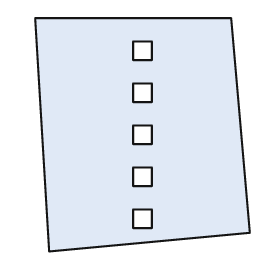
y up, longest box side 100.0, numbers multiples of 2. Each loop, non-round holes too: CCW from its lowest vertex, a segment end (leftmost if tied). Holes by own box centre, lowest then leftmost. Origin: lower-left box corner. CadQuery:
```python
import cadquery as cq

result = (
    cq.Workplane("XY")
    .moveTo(6.0, 0.0)
    .lineTo(92.0, 8.0)
    .lineTo(84.0, 100.0)
    .lineTo(0.0, 100.0)
    .close()
    .moveTo(42.0, 10.0)
    .lineTo(50.0, 10.0)
    .lineTo(50.0, 18.0)
    .lineTo(42.0, 18.0)
    .close()
    .moveTo(42.0, 28.0)
    .lineTo(50.0, 28.0)
    .lineTo(50.0, 36.0)
    .lineTo(42.0, 36.0)
    .close()
    .moveTo(42.0, 46.0)
    .lineTo(50.0, 46.0)
    .lineTo(50.0, 54.0)
    .lineTo(42.0, 54.0)
    .close()
    .moveTo(42.0, 64.0)
    .lineTo(50.0, 64.0)
    .lineTo(50.0, 72.0)
    .lineTo(42.0, 72.0)
    .close()
    .moveTo(42.0, 82.0)
    .lineTo(50.0, 82.0)
    .lineTo(50.0, 90.0)
    .lineTo(42.0, 90.0)
    .close()
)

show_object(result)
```